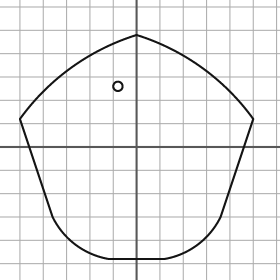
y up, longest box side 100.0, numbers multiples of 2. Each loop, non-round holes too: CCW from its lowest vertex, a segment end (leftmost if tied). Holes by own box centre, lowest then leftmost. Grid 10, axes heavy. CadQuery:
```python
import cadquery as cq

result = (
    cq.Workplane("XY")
    .moveTo(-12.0, -48.0)
    .lineTo(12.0, -48.0)
    .threePointArc((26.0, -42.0), (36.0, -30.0))
    .lineTo(50.0, 12.0)
    .threePointArc((28.0, 34.0), (0.0, 48.0))
    .threePointArc((-28.0, 34.0), (-50.0, 12.0))
    .lineTo(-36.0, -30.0)
    .threePointArc((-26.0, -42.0), (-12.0, -48.0))
    .close()
    .moveTo(-8.0, 26.0)
    .circle(2.0)
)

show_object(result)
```